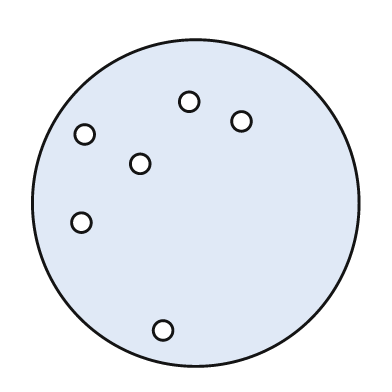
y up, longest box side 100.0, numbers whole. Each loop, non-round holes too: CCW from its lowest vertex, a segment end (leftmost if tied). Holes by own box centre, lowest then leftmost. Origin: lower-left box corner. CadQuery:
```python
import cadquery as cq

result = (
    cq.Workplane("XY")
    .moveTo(50.0, 50.0)
    .circle(50.0)
    .moveTo(40.0, 11.0)
    .circle(3.0)
    .moveTo(15.0, 44.0)
    .circle(3.0)
    .moveTo(33.0, 62.0)
    .circle(3.0)
    .moveTo(16.0, 71.0)
    .circle(3.0)
    .moveTo(64.0, 75.0)
    .circle(3.0)
    .moveTo(48.0, 81.0)
    .circle(3.0)
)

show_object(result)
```